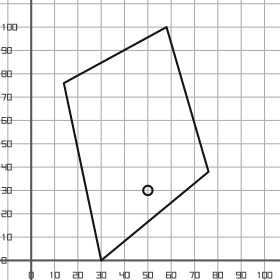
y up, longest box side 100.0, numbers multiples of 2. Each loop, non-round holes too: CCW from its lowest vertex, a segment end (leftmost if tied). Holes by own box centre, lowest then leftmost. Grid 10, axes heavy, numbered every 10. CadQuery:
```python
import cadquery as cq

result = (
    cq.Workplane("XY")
    .moveTo(30.0, 0.0)
    .lineTo(76.0, 38.0)
    .lineTo(58.0, 100.0)
    .lineTo(14.0, 76.0)
    .close()
    .moveTo(50.0, 30.0)
    .circle(2.0)
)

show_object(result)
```